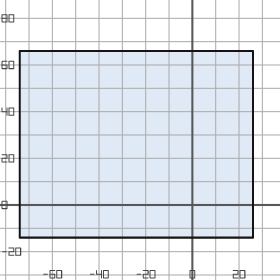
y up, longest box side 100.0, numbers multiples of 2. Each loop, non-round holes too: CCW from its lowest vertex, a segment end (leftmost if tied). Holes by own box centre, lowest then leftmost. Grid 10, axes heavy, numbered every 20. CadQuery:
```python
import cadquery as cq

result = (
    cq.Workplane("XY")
    .moveTo(-74.0, -14.0)
    .lineTo(26.0, -14.0)
    .lineTo(26.0, 66.0)
    .lineTo(-74.0, 66.0)
    .close()
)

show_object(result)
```